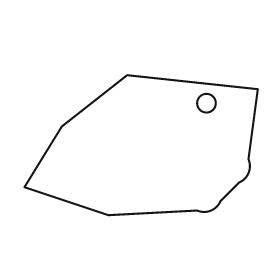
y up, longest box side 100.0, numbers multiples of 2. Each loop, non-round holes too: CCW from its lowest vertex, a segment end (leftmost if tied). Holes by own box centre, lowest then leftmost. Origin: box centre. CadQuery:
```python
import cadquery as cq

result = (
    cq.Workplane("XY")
    .moveTo(-14.0, -30.0)
    .lineTo(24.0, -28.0)
    .threePointArc((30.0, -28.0), (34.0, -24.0))
    .lineTo(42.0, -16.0)
    .threePointArc((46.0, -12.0), (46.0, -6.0))
    .lineTo(50.0, 24.0)
    .lineTo(-6.0, 30.0)
    .lineTo(-34.0, 8.0)
    .lineTo(-50.0, -18.0)
    .close()
    .moveTo(28.0, 18.0)
    .circle(4.0)
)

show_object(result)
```